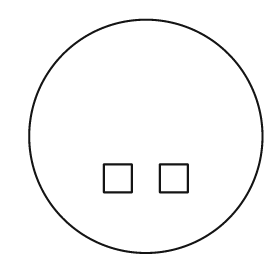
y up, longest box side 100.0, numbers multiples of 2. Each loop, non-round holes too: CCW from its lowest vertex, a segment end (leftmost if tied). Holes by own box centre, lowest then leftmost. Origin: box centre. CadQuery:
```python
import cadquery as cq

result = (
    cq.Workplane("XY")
    .moveTo(0.0, 0.0)
    .circle(50.0)
    .moveTo(-18.0, -24.0)
    .lineTo(-6.0, -24.0)
    .lineTo(-6.0, -12.0)
    .lineTo(-18.0, -12.0)
    .close()
    .moveTo(6.0, -24.0)
    .lineTo(18.0, -24.0)
    .lineTo(18.0, -12.0)
    .lineTo(6.0, -12.0)
    .close()
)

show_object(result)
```